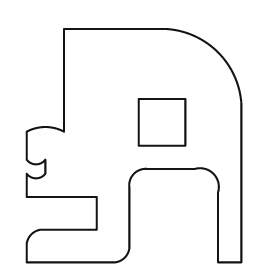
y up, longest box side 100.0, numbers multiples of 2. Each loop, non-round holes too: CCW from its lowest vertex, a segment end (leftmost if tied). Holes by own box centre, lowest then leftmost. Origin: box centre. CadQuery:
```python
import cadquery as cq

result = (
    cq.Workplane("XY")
    .moveTo(-46.0, -50.0)
    .lineTo(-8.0, -50.0)
    .threePointArc((-4.0, -48.0), (-2.0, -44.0))
    .lineTo(-2.0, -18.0)
    .threePointArc((0.0, -12.0), (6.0, -10.0))
    .lineTo(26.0, -10.0)
    .threePointArc((34.0, -12.0), (36.0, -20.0))
    .lineTo(36.0, -50.0)
    .lineTo(46.0, -50.0)
    .lineTo(46.0, 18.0)
    .threePointArc((36.0, 40.0), (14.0, 50.0))
    .lineTo(-30.0, 50.0)
    .lineTo(-30.0, 6.0)
    .threePointArc((-38.0, 8.0), (-46.0, 6.0))
    .lineTo(-46.0, -6.0)
    .threePointArc((-42.0, -8.0), (-38.0, -6.0))
    .lineTo(-38.0, -12.0)
    .threePointArc((-42.0, -14.0), (-46.0, -12.0))
    .lineTo(-46.0, -22.0)
    .lineTo(-16.0, -22.0)
    .lineTo(-16.0, -36.0)
    .lineTo(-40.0, -36.0)
    .threePointArc((-44.0, -38.0), (-46.0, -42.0))
    .close()
    .moveTo(2.0, 0.0)
    .lineTo(22.0, 0.0)
    .lineTo(22.0, 20.0)
    .lineTo(2.0, 20.0)
    .close()
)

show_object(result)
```